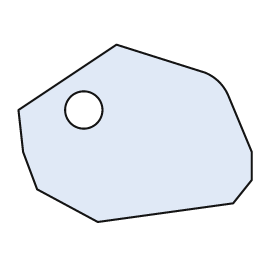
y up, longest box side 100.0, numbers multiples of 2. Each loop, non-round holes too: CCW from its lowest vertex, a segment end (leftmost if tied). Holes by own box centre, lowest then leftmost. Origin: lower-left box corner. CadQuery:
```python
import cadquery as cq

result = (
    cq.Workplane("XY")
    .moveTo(34.0, 0.0)
    .lineTo(92.0, 8.0)
    .lineTo(100.0, 18.0)
    .lineTo(100.0, 30.0)
    .lineTo(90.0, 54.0)
    .threePointArc((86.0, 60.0), (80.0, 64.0))
    .lineTo(42.0, 76.0)
    .lineTo(0.0, 48.0)
    .lineTo(2.0, 30.0)
    .lineTo(8.0, 14.0)
    .close()
    .moveTo(28.0, 48.0)
    .circle(8.0)
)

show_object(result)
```